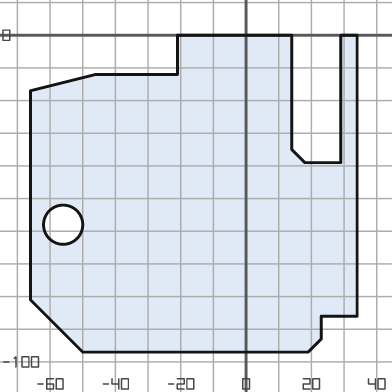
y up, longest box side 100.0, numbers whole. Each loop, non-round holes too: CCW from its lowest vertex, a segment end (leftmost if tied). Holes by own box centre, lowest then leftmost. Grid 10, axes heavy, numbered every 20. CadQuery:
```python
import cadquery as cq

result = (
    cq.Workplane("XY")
    .moveTo(-50.0, -97.0)
    .lineTo(19.0, -97.0)
    .lineTo(23.0, -93.0)
    .lineTo(23.0, -86.0)
    .lineTo(34.0, -86.0)
    .lineTo(34.0, 0.0)
    .lineTo(29.0, 0.0)
    .lineTo(29.0, -39.0)
    .lineTo(18.0, -39.0)
    .lineTo(14.0, -35.0)
    .lineTo(14.0, 0.0)
    .lineTo(-21.0, 0.0)
    .lineTo(-21.0, -12.0)
    .lineTo(-46.0, -12.0)
    .lineTo(-66.0, -17.0)
    .lineTo(-66.0, -81.0)
    .close()
    .moveTo(-56.0, -58.0)
    .circle(6.0)
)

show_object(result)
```